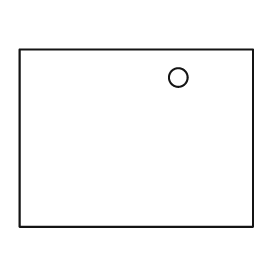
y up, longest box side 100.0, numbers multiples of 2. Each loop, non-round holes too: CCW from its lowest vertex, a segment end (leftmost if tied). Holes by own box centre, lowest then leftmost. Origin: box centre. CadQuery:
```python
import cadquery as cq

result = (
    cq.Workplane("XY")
    .moveTo(-50.0, -38.0)
    .lineTo(50.0, -38.0)
    .lineTo(50.0, 38.0)
    .lineTo(-50.0, 38.0)
    .close()
    .moveTo(18.0, 26.0)
    .circle(4.0)
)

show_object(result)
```